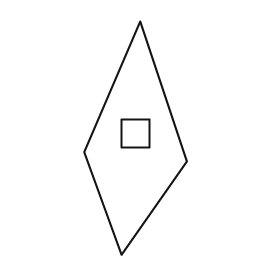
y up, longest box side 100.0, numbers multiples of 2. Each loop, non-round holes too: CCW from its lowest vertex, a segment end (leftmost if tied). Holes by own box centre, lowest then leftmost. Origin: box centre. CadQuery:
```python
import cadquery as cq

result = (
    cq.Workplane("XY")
    .moveTo(-6.0, -50.0)
    .lineTo(22.0, -10.0)
    .lineTo(2.0, 50.0)
    .lineTo(-22.0, -6.0)
    .close()
    .moveTo(-6.0, -4.0)
    .lineTo(6.0, -4.0)
    .lineTo(6.0, 8.0)
    .lineTo(-6.0, 8.0)
    .close()
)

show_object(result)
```